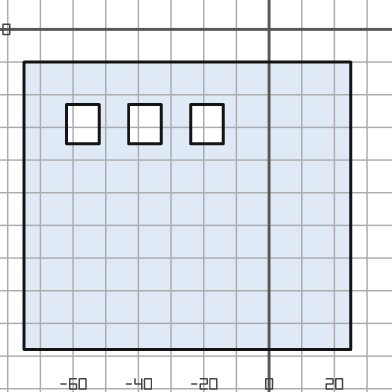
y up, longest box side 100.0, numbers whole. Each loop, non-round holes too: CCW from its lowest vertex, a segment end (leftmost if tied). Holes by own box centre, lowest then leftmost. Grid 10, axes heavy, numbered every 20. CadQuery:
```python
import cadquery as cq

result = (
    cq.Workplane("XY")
    .moveTo(-75.0, -98.0)
    .lineTo(25.0, -98.0)
    .lineTo(25.0, -10.0)
    .lineTo(-75.0, -10.0)
    .close()
    .moveTo(-62.0, -35.0)
    .lineTo(-52.0, -35.0)
    .lineTo(-52.0, -23.0)
    .lineTo(-62.0, -23.0)
    .close()
    .moveTo(-43.0, -35.0)
    .lineTo(-33.0, -35.0)
    .lineTo(-33.0, -23.0)
    .lineTo(-43.0, -23.0)
    .close()
    .moveTo(-24.0, -35.0)
    .lineTo(-14.0, -35.0)
    .lineTo(-14.0, -23.0)
    .lineTo(-24.0, -23.0)
    .close()
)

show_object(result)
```